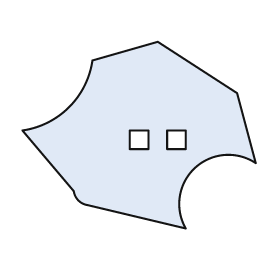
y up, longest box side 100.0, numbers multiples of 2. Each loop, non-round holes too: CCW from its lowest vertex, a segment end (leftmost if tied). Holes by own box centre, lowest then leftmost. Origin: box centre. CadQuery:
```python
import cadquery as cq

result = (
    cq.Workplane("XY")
    .moveTo(20.0, -40.0)
    .threePointArc((24.0, -14.0), (50.0, -12.0))
    .lineTo(42.0, 18.0)
    .lineTo(8.0, 40.0)
    .lineTo(-20.0, 32.0)
    .threePointArc((-30.0, 12.0), (-50.0, 2.0))
    .lineTo(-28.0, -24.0)
    .threePointArc((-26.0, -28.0), (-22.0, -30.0))
    .close()
    .moveTo(-4.0, -6.0)
    .lineTo(4.0, -6.0)
    .lineTo(4.0, 2.0)
    .lineTo(-4.0, 2.0)
    .close()
    .moveTo(12.0, -6.0)
    .lineTo(20.0, -6.0)
    .lineTo(20.0, 2.0)
    .lineTo(12.0, 2.0)
    .close()
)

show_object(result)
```